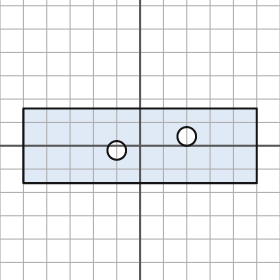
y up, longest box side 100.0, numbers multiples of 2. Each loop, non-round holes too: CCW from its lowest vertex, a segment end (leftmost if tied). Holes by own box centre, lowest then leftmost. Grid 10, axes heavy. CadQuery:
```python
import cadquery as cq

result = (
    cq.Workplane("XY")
    .moveTo(-50.0, -16.0)
    .lineTo(50.0, -16.0)
    .lineTo(50.0, 16.0)
    .lineTo(-50.0, 16.0)
    .close()
    .moveTo(-10.0, -2.0)
    .circle(4.0)
    .moveTo(20.0, 4.0)
    .circle(4.0)
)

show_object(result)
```